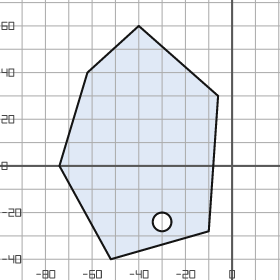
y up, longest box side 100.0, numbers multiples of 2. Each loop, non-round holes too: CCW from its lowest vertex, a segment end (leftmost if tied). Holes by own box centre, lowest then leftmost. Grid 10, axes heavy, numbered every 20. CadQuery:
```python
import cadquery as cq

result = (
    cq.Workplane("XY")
    .moveTo(-52.0, -40.0)
    .lineTo(-10.0, -28.0)
    .lineTo(-6.0, 30.0)
    .lineTo(-40.0, 60.0)
    .lineTo(-62.0, 40.0)
    .lineTo(-74.0, 0.0)
    .close()
    .moveTo(-30.0, -24.0)
    .circle(4.0)
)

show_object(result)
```